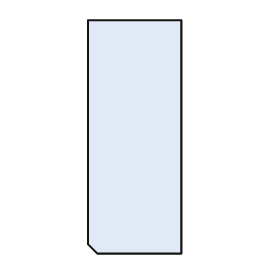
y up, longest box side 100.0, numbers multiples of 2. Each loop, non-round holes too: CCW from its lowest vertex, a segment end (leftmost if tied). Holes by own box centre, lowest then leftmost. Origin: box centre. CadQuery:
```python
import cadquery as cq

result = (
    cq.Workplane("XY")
    .moveTo(-16.0, -50.0)
    .lineTo(20.0, -50.0)
    .lineTo(20.0, 50.0)
    .lineTo(-20.0, 50.0)
    .lineTo(-20.0, -46.0)
    .close()
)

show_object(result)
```